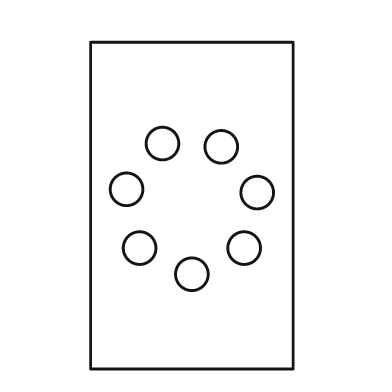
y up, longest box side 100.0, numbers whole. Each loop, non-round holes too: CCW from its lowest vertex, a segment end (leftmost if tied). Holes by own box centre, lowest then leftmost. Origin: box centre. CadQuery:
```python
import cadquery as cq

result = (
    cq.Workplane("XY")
    .moveTo(-31.0, -50.0)
    .lineTo(31.0, -50.0)
    .lineTo(31.0, 50.0)
    .lineTo(-31.0, 50.0)
    .close()
    .moveTo(0.0, -21.0)
    .circle(5.0)
    .moveTo(-16.0, -13.0)
    .circle(5.0)
    .moveTo(16.0, -13.0)
    .circle(5.0)
    .moveTo(20.0, 4.0)
    .circle(5.0)
    .moveTo(-20.0, 5.0)
    .circle(5.0)
    .moveTo(9.0, 18.0)
    .circle(5.0)
    .moveTo(-9.0, 19.0)
    .circle(5.0)
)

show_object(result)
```